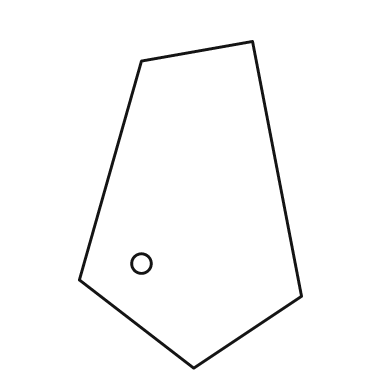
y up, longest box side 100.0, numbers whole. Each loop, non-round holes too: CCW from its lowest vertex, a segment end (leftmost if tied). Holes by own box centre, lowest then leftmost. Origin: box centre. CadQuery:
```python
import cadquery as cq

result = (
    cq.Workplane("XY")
    .moveTo(1.0, -50.0)
    .lineTo(34.0, -28.0)
    .lineTo(19.0, 50.0)
    .lineTo(-15.0, 44.0)
    .lineTo(-34.0, -23.0)
    .close()
    .moveTo(-15.0, -18.0)
    .circle(3.0)
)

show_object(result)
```